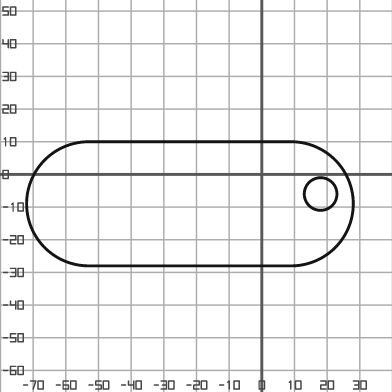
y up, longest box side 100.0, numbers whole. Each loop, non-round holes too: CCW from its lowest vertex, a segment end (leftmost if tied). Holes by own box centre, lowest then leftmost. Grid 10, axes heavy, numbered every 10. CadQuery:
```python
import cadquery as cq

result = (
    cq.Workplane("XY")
    .moveTo(-53.0, -28.0)
    .lineTo(9.0, -28.0)
    .threePointArc((28.0, -9.0), (9.0, 10.0))
    .lineTo(-53.0, 10.0)
    .threePointArc((-72.0, -9.0), (-53.0, -28.0))
    .close()
    .moveTo(18.0, -6.0)
    .circle(5.0)
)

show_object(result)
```